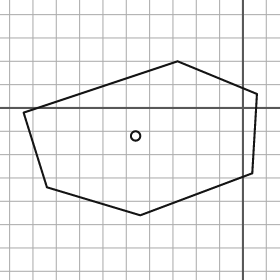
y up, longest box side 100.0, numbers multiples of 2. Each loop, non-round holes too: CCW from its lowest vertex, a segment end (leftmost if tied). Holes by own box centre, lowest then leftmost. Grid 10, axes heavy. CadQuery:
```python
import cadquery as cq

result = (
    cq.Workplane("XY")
    .moveTo(-44.0, -46.0)
    .lineTo(4.0, -28.0)
    .lineTo(6.0, 6.0)
    .lineTo(-28.0, 20.0)
    .lineTo(-94.0, -2.0)
    .lineTo(-84.0, -34.0)
    .close()
    .moveTo(-46.0, -12.0)
    .circle(2.0)
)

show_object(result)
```